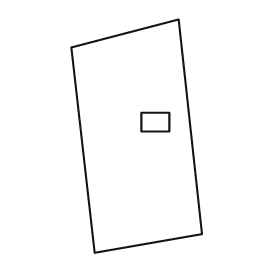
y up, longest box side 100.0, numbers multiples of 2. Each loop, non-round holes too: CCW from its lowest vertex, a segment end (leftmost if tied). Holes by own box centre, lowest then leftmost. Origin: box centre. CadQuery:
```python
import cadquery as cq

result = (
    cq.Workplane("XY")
    .moveTo(-18.0, -50.0)
    .lineTo(28.0, -42.0)
    .lineTo(18.0, 50.0)
    .lineTo(-28.0, 38.0)
    .close()
    .moveTo(2.0, 2.0)
    .lineTo(14.0, 2.0)
    .lineTo(14.0, 10.0)
    .lineTo(2.0, 10.0)
    .close()
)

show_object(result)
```